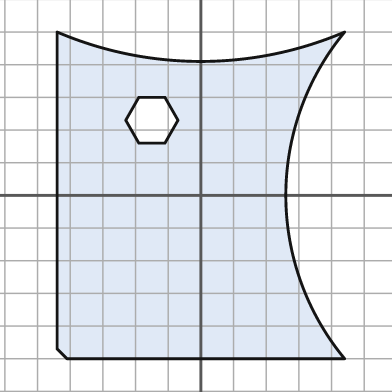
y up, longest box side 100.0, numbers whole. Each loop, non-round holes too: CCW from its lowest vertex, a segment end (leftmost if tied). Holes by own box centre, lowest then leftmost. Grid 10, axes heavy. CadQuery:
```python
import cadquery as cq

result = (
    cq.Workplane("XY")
    .moveTo(-41.0, -50.0)
    .lineTo(44.0, -50.0)
    .threePointArc((26.0, 0.0), (44.0, 50.0))
    .threePointArc((0.0, 41.0), (-44.0, 50.0))
    .lineTo(-44.0, -47.0)
    .close()
    .moveTo(-19.0, 16.0)
    .lineTo(-11.0, 16.0)
    .lineTo(-7.0, 23.0)
    .lineTo(-11.0, 30.0)
    .lineTo(-19.0, 30.0)
    .lineTo(-23.0, 23.0)
    .close()
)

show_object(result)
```